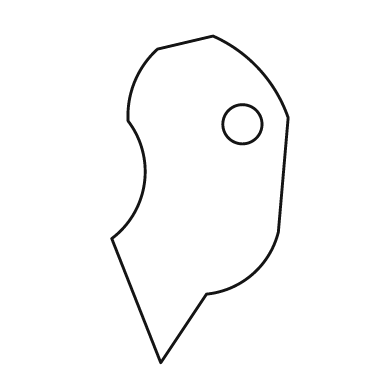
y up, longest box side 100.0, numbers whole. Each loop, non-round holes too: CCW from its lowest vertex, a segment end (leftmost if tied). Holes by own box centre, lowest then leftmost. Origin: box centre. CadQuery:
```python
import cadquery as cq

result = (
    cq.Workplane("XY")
    .moveTo(-12.0, -50.0)
    .lineTo(2.0, -29.0)
    .threePointArc((16.0, -23.0), (24.0, -10.0))
    .lineTo(27.0, 25.0)
    .threePointArc((18.0, 40.0), (4.0, 50.0))
    .lineTo(-13.0, 46.0)
    .threePointArc((-20.0, 36.0), (-22.0, 24.0))
    .threePointArc((-17.0, 5.0), (-27.0, -12.0))
    .close()
    .moveTo(13.0, 23.0)
    .circle(6.0)
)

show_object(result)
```